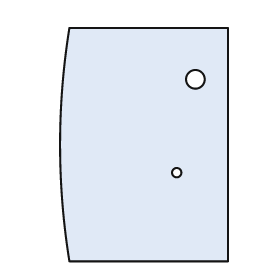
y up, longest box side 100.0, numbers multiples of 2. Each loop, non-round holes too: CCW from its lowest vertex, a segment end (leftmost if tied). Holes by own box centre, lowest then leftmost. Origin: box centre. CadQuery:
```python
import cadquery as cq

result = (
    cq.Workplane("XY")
    .moveTo(-32.0, -50.0)
    .lineTo(36.0, -50.0)
    .lineTo(36.0, 50.0)
    .lineTo(-32.0, 50.0)
    .threePointArc((-36.0, 0.0), (-32.0, -50.0))
    .close()
    .moveTo(14.0, -12.0)
    .circle(2.0)
    .moveTo(22.0, 28.0)
    .circle(4.0)
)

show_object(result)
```